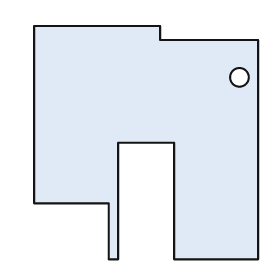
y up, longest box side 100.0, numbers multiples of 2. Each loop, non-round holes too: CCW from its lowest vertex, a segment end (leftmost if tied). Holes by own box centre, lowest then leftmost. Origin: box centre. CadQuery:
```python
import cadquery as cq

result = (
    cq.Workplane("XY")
    .moveTo(-16.0, -50.0)
    .lineTo(-12.0, -50.0)
    .lineTo(-12.0, 0.0)
    .lineTo(12.0, 0.0)
    .lineTo(12.0, -50.0)
    .lineTo(48.0, -50.0)
    .lineTo(48.0, 44.0)
    .lineTo(6.0, 44.0)
    .lineTo(6.0, 50.0)
    .lineTo(-48.0, 50.0)
    .lineTo(-48.0, -26.0)
    .lineTo(-16.0, -26.0)
    .close()
    .moveTo(40.0, 28.0)
    .circle(4.0)
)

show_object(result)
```